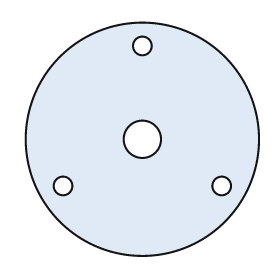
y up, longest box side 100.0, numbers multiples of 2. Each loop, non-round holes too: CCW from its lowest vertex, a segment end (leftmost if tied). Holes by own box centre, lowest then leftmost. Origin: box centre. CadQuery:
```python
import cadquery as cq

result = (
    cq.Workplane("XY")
    .moveTo(0.0, 0.0)
    .circle(50.0)
    .moveTo(-34.0, -20.0)
    .circle(4.0)
    .moveTo(34.0, -20.0)
    .circle(4.0)
    .moveTo(0.0, 0.0)
    .circle(8.0)
    .moveTo(0.0, 40.0)
    .circle(4.0)
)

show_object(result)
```